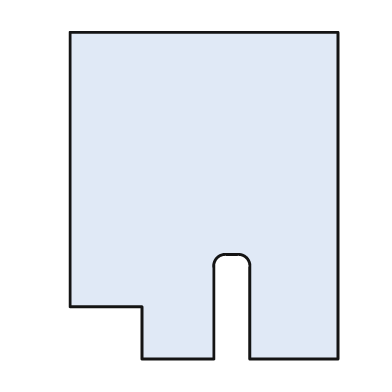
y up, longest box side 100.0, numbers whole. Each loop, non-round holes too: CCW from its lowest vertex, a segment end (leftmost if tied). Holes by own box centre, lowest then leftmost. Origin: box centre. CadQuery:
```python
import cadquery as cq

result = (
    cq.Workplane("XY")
    .moveTo(-19.0, -50.0)
    .lineTo(3.0, -50.0)
    .lineTo(3.0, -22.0)
    .threePointArc((4.0, -19.0), (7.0, -18.0))
    .lineTo(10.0, -18.0)
    .threePointArc((13.0, -19.0), (14.0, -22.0))
    .lineTo(14.0, -50.0)
    .lineTo(41.0, -50.0)
    .lineTo(41.0, 50.0)
    .lineTo(-41.0, 50.0)
    .lineTo(-41.0, -34.0)
    .lineTo(-19.0, -34.0)
    .close()
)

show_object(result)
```